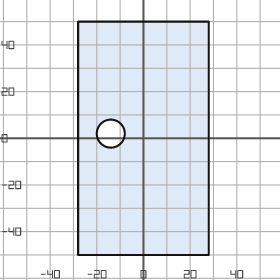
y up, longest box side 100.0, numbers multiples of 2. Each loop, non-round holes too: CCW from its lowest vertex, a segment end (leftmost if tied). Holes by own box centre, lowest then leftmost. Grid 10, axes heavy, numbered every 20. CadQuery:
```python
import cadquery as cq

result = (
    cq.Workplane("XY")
    .moveTo(-28.0, -50.0)
    .lineTo(28.0, -50.0)
    .lineTo(28.0, 50.0)
    .lineTo(-28.0, 50.0)
    .close()
    .moveTo(-14.0, 2.0)
    .circle(6.0)
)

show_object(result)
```